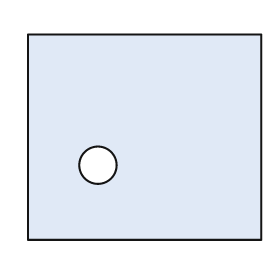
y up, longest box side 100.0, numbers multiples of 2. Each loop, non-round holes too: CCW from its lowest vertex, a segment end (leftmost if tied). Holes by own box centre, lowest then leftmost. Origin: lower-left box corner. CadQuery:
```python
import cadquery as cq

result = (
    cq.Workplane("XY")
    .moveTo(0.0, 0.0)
    .lineTo(100.0, 0.0)
    .lineTo(100.0, 88.0)
    .lineTo(0.0, 88.0)
    .close()
    .moveTo(30.0, 32.0)
    .circle(8.0)
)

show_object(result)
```